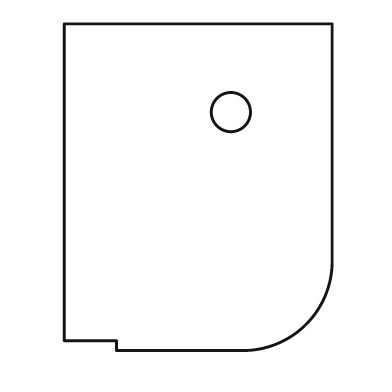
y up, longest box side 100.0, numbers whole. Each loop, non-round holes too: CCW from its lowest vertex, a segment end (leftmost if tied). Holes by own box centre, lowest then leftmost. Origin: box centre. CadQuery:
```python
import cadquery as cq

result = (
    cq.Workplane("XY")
    .moveTo(-25.0, -50.0)
    .lineTo(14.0, -50.0)
    .threePointArc((33.0, -42.0), (41.0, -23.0))
    .lineTo(41.0, 50.0)
    .lineTo(-41.0, 50.0)
    .lineTo(-41.0, -47.0)
    .lineTo(-25.0, -47.0)
    .close()
    .moveTo(10.0, 23.0)
    .circle(6.0)
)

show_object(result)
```